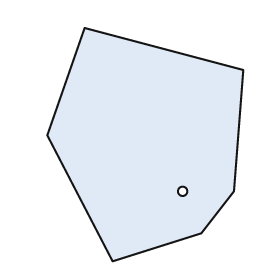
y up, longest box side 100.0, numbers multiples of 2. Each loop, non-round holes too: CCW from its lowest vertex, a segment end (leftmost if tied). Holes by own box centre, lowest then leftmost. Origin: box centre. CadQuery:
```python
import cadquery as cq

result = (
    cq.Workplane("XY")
    .moveTo(-14.0, -50.0)
    .lineTo(24.0, -38.0)
    .lineTo(38.0, -20.0)
    .lineTo(42.0, 32.0)
    .lineTo(-26.0, 50.0)
    .lineTo(-42.0, 4.0)
    .close()
    .moveTo(16.0, -20.0)
    .circle(2.0)
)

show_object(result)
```